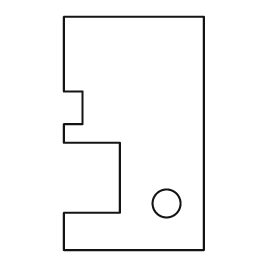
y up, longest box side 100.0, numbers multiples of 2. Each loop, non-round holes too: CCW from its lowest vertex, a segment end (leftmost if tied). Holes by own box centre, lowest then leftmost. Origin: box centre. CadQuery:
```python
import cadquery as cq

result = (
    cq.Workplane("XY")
    .moveTo(-30.0, -50.0)
    .lineTo(30.0, -50.0)
    .lineTo(30.0, 50.0)
    .lineTo(-30.0, 50.0)
    .lineTo(-30.0, 18.0)
    .lineTo(-22.0, 18.0)
    .lineTo(-22.0, 4.0)
    .lineTo(-30.0, 4.0)
    .lineTo(-30.0, -4.0)
    .lineTo(-6.0, -4.0)
    .lineTo(-6.0, -34.0)
    .lineTo(-30.0, -34.0)
    .close()
    .moveTo(14.0, -30.0)
    .circle(6.0)
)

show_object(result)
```